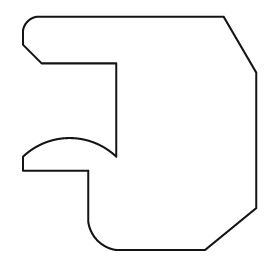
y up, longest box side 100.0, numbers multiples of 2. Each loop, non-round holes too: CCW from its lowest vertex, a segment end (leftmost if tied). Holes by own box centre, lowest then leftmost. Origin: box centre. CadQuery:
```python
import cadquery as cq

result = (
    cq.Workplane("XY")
    .moveTo(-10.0, -50.0)
    .lineTo(28.0, -50.0)
    .lineTo(50.0, -32.0)
    .lineTo(50.0, 26.0)
    .lineTo(36.0, 50.0)
    .lineTo(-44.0, 50.0)
    .threePointArc((-48.0, 48.0), (-50.0, 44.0))
    .lineTo(-50.0, 38.0)
    .lineTo(-42.0, 30.0)
    .lineTo(-10.0, 30.0)
    .lineTo(-10.0, -10.0)
    .threePointArc((-30.0, -2.0), (-50.0, -10.0))
    .lineTo(-50.0, -16.0)
    .lineTo(-22.0, -16.0)
    .lineTo(-22.0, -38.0)
    .threePointArc((-18.0, -46.0), (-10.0, -50.0))
    .close()
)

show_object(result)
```